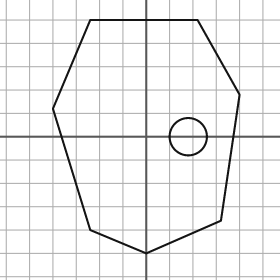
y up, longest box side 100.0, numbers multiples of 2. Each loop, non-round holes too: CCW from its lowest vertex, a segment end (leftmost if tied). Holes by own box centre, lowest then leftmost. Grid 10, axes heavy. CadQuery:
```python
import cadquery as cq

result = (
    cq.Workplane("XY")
    .moveTo(0.0, -50.0)
    .lineTo(32.0, -36.0)
    .lineTo(40.0, 18.0)
    .lineTo(22.0, 50.0)
    .lineTo(-24.0, 50.0)
    .lineTo(-40.0, 12.0)
    .lineTo(-24.0, -40.0)
    .close()
    .moveTo(18.0, 0.0)
    .circle(8.0)
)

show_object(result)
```